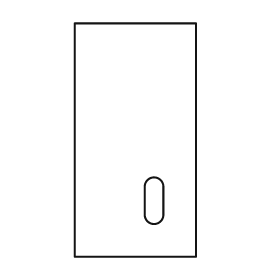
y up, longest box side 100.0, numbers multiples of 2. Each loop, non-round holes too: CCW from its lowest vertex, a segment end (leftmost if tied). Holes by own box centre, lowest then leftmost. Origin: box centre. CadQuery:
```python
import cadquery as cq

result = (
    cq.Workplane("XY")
    .moveTo(-26.0, -50.0)
    .lineTo(26.0, -50.0)
    .lineTo(26.0, 50.0)
    .lineTo(-26.0, 50.0)
    .close()
    .moveTo(4.0, -32.0)
    .threePointArc((8.0, -36.0), (12.0, -32.0))
    .lineTo(12.0, -20.0)
    .threePointArc((8.0, -16.0), (4.0, -20.0))
    .close()
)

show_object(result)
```